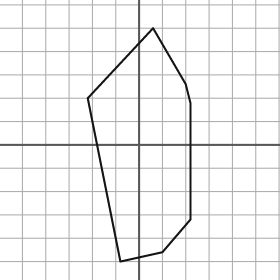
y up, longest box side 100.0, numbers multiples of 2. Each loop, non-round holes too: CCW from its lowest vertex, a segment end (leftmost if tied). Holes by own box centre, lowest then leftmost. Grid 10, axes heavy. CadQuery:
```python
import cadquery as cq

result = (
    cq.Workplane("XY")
    .moveTo(-8.0, -50.0)
    .lineTo(10.0, -46.0)
    .lineTo(22.0, -32.0)
    .lineTo(22.0, 18.0)
    .lineTo(20.0, 26.0)
    .lineTo(6.0, 50.0)
    .lineTo(-22.0, 20.0)
    .close()
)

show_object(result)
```